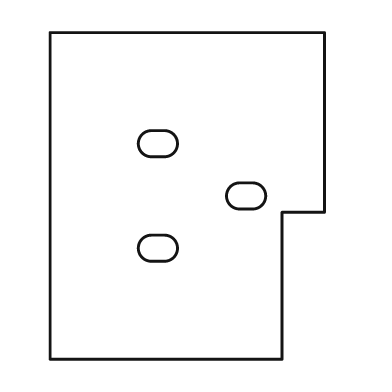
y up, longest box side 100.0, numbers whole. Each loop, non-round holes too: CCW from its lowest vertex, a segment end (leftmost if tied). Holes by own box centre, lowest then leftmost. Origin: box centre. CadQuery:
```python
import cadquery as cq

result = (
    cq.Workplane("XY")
    .moveTo(-42.0, -50.0)
    .lineTo(29.0, -50.0)
    .lineTo(29.0, -5.0)
    .lineTo(42.0, -5.0)
    .lineTo(42.0, 50.0)
    .lineTo(-42.0, 50.0)
    .close()
    .moveTo(-11.0, -20.0)
    .lineTo(-7.0, -20.0)
    .threePointArc((-3.0, -16.0), (-7.0, -12.0))
    .lineTo(-11.0, -12.0)
    .threePointArc((-15.0, -16.0), (-11.0, -20.0))
    .close()
    .moveTo(16.0, -4.0)
    .lineTo(20.0, -4.0)
    .threePointArc((24.0, 0.0), (20.0, 4.0))
    .lineTo(16.0, 4.0)
    .threePointArc((12.0, 0.0), (16.0, -4.0))
    .close()
    .moveTo(-11.0, 12.0)
    .lineTo(-7.0, 12.0)
    .threePointArc((-3.0, 16.0), (-7.0, 20.0))
    .lineTo(-11.0, 20.0)
    .threePointArc((-15.0, 16.0), (-11.0, 12.0))
    .close()
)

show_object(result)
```